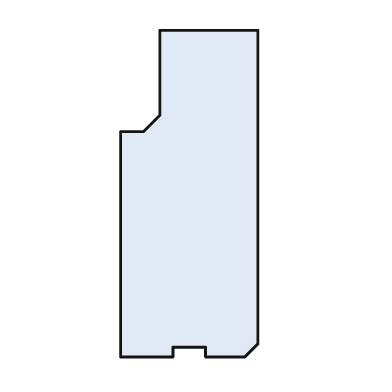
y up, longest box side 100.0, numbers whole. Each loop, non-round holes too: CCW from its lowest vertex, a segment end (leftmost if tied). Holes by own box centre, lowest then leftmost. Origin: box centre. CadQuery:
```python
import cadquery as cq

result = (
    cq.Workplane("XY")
    .moveTo(-21.0, -50.0)
    .lineTo(-5.0, -50.0)
    .lineTo(-5.0, -47.0)
    .lineTo(5.0, -47.0)
    .lineTo(5.0, -50.0)
    .lineTo(17.0, -50.0)
    .lineTo(21.0, -46.0)
    .lineTo(21.0, 50.0)
    .lineTo(-9.0, 50.0)
    .lineTo(-9.0, 24.0)
    .lineTo(-14.0, 19.0)
    .lineTo(-21.0, 19.0)
    .close()
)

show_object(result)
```